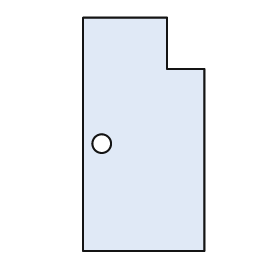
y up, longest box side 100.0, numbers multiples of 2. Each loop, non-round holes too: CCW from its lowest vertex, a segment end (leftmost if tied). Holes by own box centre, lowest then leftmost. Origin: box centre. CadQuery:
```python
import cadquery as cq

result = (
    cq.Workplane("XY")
    .moveTo(-26.0, -50.0)
    .lineTo(26.0, -50.0)
    .lineTo(26.0, 28.0)
    .lineTo(10.0, 28.0)
    .lineTo(10.0, 50.0)
    .lineTo(-26.0, 50.0)
    .close()
    .moveTo(-18.0, -4.0)
    .circle(4.0)
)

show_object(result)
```